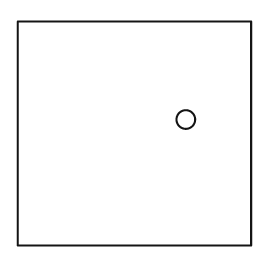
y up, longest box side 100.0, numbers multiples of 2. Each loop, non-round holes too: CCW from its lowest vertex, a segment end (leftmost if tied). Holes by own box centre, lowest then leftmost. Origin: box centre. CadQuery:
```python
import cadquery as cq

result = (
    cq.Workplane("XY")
    .moveTo(-50.0, -48.0)
    .lineTo(50.0, -48.0)
    .lineTo(50.0, 48.0)
    .lineTo(-50.0, 48.0)
    .close()
    .moveTo(22.0, 6.0)
    .circle(4.0)
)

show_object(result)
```